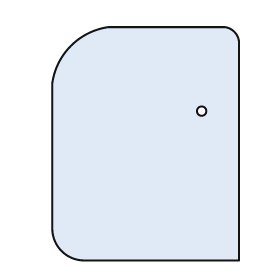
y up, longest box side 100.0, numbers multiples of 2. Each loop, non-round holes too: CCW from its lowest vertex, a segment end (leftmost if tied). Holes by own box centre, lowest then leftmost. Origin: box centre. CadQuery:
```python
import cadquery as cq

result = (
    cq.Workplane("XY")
    .moveTo(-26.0, -50.0)
    .lineTo(40.0, -50.0)
    .lineTo(40.0, 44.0)
    .threePointArc((38.0, 48.0), (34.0, 50.0))
    .lineTo(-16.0, 50.0)
    .threePointArc((-32.0, 42.0), (-40.0, 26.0))
    .lineTo(-40.0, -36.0)
    .threePointArc((-36.0, -46.0), (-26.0, -50.0))
    .close()
    .moveTo(24.0, 14.0)
    .circle(2.0)
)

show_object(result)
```